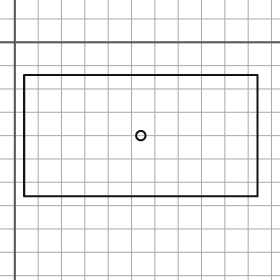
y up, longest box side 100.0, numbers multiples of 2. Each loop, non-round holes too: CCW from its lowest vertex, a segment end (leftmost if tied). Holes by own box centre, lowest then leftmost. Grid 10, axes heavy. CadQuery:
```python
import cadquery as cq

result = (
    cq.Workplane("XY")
    .moveTo(4.0, -66.0)
    .lineTo(104.0, -66.0)
    .lineTo(104.0, -14.0)
    .lineTo(4.0, -14.0)
    .close()
    .moveTo(54.0, -40.0)
    .circle(2.0)
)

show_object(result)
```